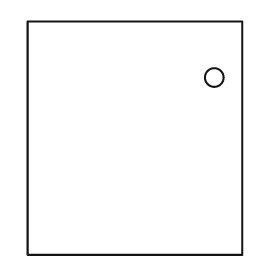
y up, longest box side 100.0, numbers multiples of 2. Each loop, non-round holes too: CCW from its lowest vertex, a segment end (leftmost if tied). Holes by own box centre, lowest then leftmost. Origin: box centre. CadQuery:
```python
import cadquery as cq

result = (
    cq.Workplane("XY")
    .moveTo(-46.0, -50.0)
    .lineTo(46.0, -50.0)
    .lineTo(46.0, 50.0)
    .lineTo(-46.0, 50.0)
    .close()
    .moveTo(34.0, 26.0)
    .circle(4.0)
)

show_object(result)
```